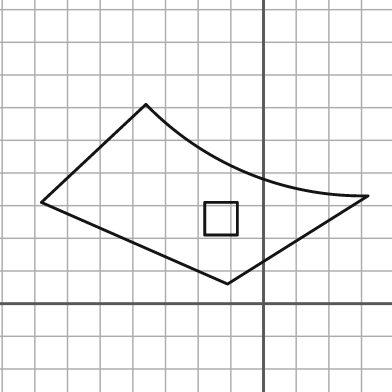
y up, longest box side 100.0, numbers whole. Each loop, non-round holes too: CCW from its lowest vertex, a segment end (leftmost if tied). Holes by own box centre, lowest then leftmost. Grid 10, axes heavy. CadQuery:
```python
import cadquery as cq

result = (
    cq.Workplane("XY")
    .moveTo(-11.0, 6.0)
    .lineTo(32.0, 33.0)
    .threePointArc((-5.0, 40.0), (-36.0, 61.0))
    .lineTo(-68.0, 31.0)
    .close()
    .moveTo(-18.0, 21.0)
    .lineTo(-8.0, 21.0)
    .lineTo(-8.0, 31.0)
    .lineTo(-18.0, 31.0)
    .close()
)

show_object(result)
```